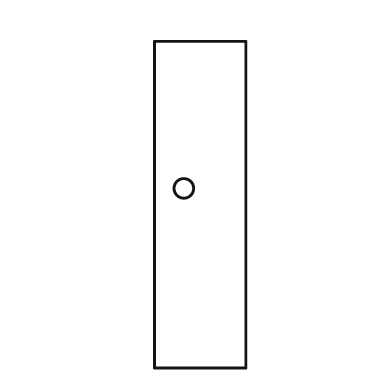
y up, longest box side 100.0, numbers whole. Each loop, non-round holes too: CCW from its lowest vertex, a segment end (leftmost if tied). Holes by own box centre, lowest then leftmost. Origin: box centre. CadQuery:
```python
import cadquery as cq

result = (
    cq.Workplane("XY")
    .moveTo(-14.0, -50.0)
    .lineTo(14.0, -50.0)
    .lineTo(14.0, 50.0)
    .lineTo(-14.0, 50.0)
    .close()
    .moveTo(-5.0, 5.0)
    .circle(3.0)
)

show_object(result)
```